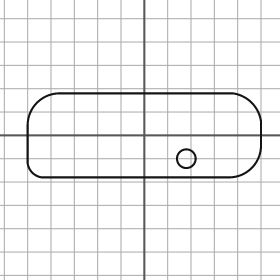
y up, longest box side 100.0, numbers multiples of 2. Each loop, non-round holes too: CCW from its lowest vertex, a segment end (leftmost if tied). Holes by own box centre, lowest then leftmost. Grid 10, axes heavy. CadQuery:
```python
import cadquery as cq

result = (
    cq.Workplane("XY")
    .moveTo(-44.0, -18.0)
    .lineTo(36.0, -18.0)
    .threePointArc((46.0, -14.0), (50.0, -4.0))
    .lineTo(50.0, 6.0)
    .threePointArc((46.0, 14.0), (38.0, 18.0))
    .lineTo(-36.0, 18.0)
    .threePointArc((-46.0, 14.0), (-50.0, 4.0))
    .lineTo(-50.0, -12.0)
    .threePointArc((-48.0, -16.0), (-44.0, -18.0))
    .close()
    .moveTo(18.0, -10.0)
    .circle(4.0)
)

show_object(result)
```